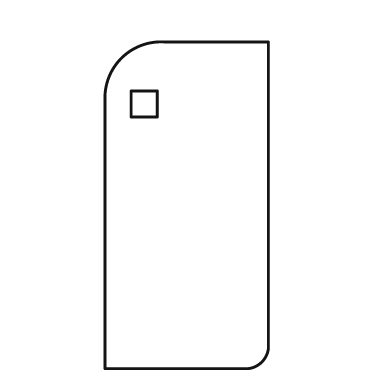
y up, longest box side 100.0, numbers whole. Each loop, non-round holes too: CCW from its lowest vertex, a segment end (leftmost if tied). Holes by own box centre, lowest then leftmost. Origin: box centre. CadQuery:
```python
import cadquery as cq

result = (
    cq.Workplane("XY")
    .moveTo(-25.0, -50.0)
    .lineTo(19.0, -50.0)
    .threePointArc((23.0, -48.0), (25.0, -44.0))
    .lineTo(25.0, 50.0)
    .lineTo(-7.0, 50.0)
    .threePointArc((-20.0, 45.0), (-25.0, 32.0))
    .close()
    .moveTo(-17.0, 27.0)
    .lineTo(-9.0, 27.0)
    .lineTo(-9.0, 35.0)
    .lineTo(-17.0, 35.0)
    .close()
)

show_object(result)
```